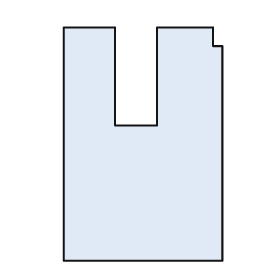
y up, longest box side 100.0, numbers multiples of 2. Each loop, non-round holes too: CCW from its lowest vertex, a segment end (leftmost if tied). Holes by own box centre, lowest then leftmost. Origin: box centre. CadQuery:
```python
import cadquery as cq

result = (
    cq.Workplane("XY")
    .moveTo(-34.0, -50.0)
    .lineTo(34.0, -50.0)
    .lineTo(34.0, 42.0)
    .lineTo(30.0, 42.0)
    .lineTo(30.0, 50.0)
    .lineTo(6.0, 50.0)
    .lineTo(6.0, 8.0)
    .lineTo(-12.0, 8.0)
    .lineTo(-12.0, 50.0)
    .lineTo(-34.0, 50.0)
    .close()
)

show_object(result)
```